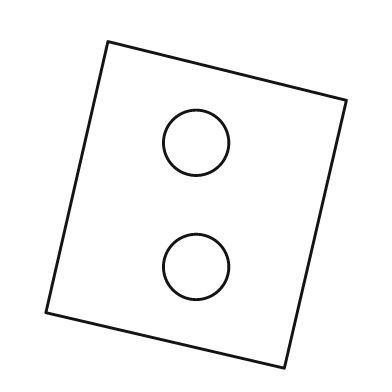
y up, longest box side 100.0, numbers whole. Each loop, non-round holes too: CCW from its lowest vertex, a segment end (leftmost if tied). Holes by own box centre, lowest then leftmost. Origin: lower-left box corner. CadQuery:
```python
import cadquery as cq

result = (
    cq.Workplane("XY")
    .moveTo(73.0, 0.0)
    .lineTo(92.0, 82.0)
    .lineTo(19.0, 100.0)
    .lineTo(0.0, 17.0)
    .close()
    .moveTo(46.0, 31.0)
    .circle(10.0)
    .moveTo(46.0, 69.0)
    .circle(10.0)
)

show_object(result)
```